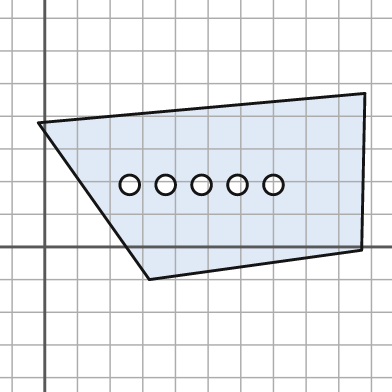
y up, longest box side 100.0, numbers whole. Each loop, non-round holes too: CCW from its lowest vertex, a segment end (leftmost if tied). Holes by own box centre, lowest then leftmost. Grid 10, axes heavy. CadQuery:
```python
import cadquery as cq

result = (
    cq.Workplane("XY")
    .moveTo(32.0, -10.0)
    .lineTo(97.0, -1.0)
    .lineTo(98.0, 47.0)
    .lineTo(-2.0, 38.0)
    .close()
    .moveTo(26.0, 19.0)
    .circle(3.0)
    .moveTo(37.0, 19.0)
    .circle(3.0)
    .moveTo(48.0, 19.0)
    .circle(3.0)
    .moveTo(59.0, 19.0)
    .circle(3.0)
    .moveTo(70.0, 19.0)
    .circle(3.0)
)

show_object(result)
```